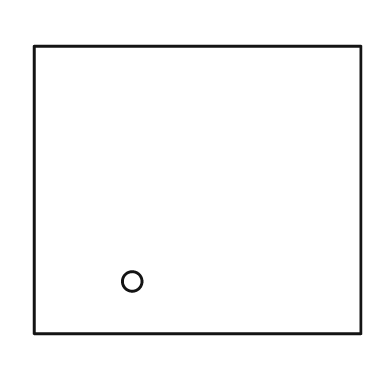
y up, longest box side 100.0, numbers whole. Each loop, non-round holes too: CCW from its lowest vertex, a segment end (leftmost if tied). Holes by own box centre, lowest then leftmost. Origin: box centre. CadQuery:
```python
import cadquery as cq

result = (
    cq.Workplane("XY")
    .moveTo(-50.0, -44.0)
    .lineTo(50.0, -44.0)
    .lineTo(50.0, 44.0)
    .lineTo(-50.0, 44.0)
    .close()
    .moveTo(-20.0, -28.0)
    .circle(3.0)
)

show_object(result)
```